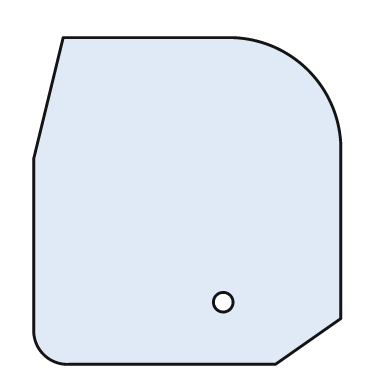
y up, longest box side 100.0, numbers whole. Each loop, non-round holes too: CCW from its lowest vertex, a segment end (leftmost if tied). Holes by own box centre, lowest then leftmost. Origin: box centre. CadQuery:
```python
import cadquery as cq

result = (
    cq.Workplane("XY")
    .moveTo(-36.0, -50.0)
    .lineTo(27.0, -50.0)
    .lineTo(47.0, -36.0)
    .lineTo(47.0, 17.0)
    .threePointArc((37.0, 40.0), (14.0, 50.0))
    .lineTo(-38.0, 50.0)
    .lineTo(-47.0, 13.0)
    .lineTo(-47.0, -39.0)
    .threePointArc((-44.0, -47.0), (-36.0, -50.0))
    .close()
    .moveTo(11.0, -31.0)
    .circle(3.0)
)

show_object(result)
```